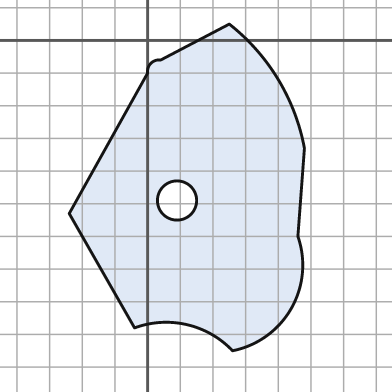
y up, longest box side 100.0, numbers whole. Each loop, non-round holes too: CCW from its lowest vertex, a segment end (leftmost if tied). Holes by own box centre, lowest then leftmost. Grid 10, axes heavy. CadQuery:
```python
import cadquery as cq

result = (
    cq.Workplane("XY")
    .moveTo(26.0, -95.0)
    .threePointArc((44.0, -82.0), (46.0, -60.0))
    .lineTo(48.0, -33.0)
    .threePointArc((40.0, -12.0), (25.0, 5.0))
    .lineTo(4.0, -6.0)
    .threePointArc((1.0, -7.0), (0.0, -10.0))
    .lineTo(-24.0, -53.0)
    .lineTo(-4.0, -88.0)
    .threePointArc((12.0, -87.0), (26.0, -95.0))
    .close()
    .moveTo(9.0, -49.0)
    .circle(6.0)
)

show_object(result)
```